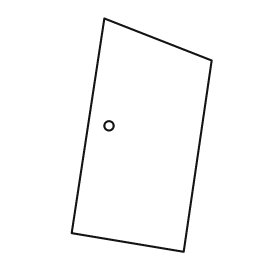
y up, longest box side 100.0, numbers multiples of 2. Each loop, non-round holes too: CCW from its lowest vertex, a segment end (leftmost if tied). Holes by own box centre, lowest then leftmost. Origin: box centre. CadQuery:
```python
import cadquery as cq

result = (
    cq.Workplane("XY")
    .moveTo(18.0, -50.0)
    .lineTo(30.0, 32.0)
    .lineTo(-16.0, 50.0)
    .lineTo(-30.0, -42.0)
    .close()
    .moveTo(-14.0, 4.0)
    .circle(2.0)
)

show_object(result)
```